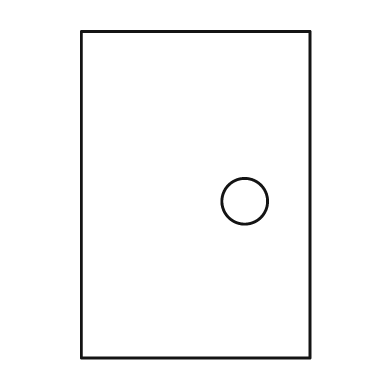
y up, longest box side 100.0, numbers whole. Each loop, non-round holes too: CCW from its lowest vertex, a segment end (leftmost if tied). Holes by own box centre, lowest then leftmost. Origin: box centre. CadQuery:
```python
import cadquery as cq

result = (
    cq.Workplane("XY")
    .moveTo(-35.0, -50.0)
    .lineTo(35.0, -50.0)
    .lineTo(35.0, 50.0)
    .lineTo(-35.0, 50.0)
    .close()
    .moveTo(15.0, -2.0)
    .circle(7.0)
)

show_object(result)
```